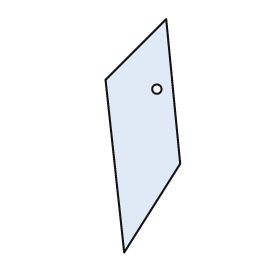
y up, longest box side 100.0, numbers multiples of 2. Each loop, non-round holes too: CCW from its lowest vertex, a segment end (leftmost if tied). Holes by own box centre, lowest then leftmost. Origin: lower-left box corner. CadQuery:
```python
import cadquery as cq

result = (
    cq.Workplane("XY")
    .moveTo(8.0, 0.0)
    .lineTo(32.0, 38.0)
    .lineTo(26.0, 100.0)
    .lineTo(0.0, 74.0)
    .close()
    .moveTo(22.0, 70.0)
    .circle(2.0)
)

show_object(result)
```